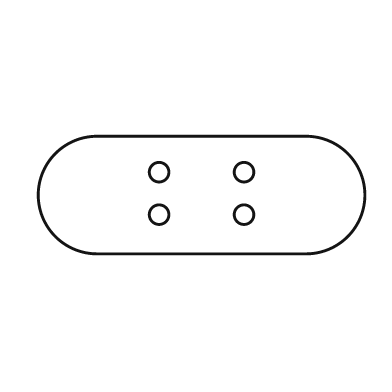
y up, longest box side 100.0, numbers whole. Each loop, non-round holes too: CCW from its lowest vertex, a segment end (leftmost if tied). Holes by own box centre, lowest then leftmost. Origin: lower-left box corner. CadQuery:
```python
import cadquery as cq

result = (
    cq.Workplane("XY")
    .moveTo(18.0, 0.0)
    .lineTo(82.0, 0.0)
    .threePointArc((100.0, 18.0), (82.0, 36.0))
    .lineTo(18.0, 36.0)
    .threePointArc((0.0, 18.0), (18.0, 0.0))
    .close()
    .moveTo(37.0, 12.0)
    .circle(3.0)
    .moveTo(63.0, 12.0)
    .circle(3.0)
    .moveTo(37.0, 25.0)
    .circle(3.0)
    .moveTo(63.0, 25.0)
    .circle(3.0)
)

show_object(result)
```